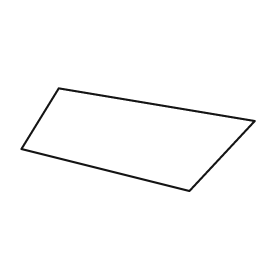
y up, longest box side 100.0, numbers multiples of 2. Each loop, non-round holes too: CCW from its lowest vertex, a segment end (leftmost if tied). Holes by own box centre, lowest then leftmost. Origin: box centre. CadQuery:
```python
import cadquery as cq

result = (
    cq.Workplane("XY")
    .moveTo(22.0, -22.0)
    .lineTo(50.0, 8.0)
    .lineTo(-34.0, 22.0)
    .lineTo(-50.0, -4.0)
    .close()
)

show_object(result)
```